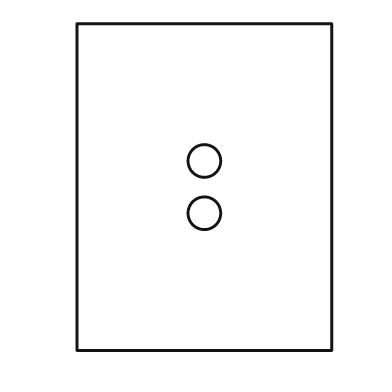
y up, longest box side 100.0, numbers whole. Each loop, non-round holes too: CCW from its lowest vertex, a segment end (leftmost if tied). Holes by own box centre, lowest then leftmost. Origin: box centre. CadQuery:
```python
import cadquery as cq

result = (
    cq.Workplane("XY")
    .moveTo(-39.0, -50.0)
    .lineTo(39.0, -50.0)
    .lineTo(39.0, 50.0)
    .lineTo(-39.0, 50.0)
    .close()
    .moveTo(0.0, -8.0)
    .circle(5.0)
    .moveTo(0.0, 8.0)
    .circle(5.0)
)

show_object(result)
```